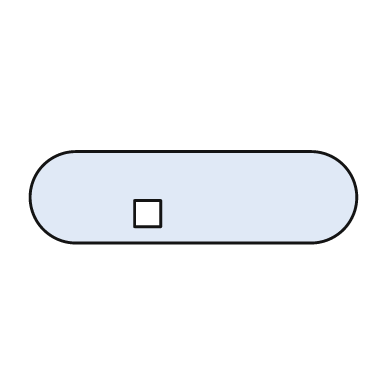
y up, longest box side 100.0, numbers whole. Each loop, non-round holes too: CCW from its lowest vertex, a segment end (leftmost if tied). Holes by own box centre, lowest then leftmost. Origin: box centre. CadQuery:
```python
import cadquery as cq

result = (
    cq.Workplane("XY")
    .moveTo(-36.0, -14.0)
    .lineTo(36.0, -14.0)
    .threePointArc((50.0, 0.0), (36.0, 14.0))
    .lineTo(-36.0, 14.0)
    .threePointArc((-50.0, 0.0), (-36.0, -14.0))
    .close()
    .moveTo(-18.0, -9.0)
    .lineTo(-10.0, -9.0)
    .lineTo(-10.0, -1.0)
    .lineTo(-18.0, -1.0)
    .close()
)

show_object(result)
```